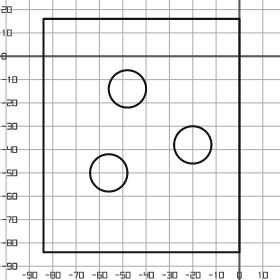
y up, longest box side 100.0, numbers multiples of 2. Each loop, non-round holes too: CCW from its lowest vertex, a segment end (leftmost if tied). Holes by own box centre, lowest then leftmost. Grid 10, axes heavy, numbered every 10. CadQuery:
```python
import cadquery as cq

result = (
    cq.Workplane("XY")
    .moveTo(-84.0, -84.0)
    .lineTo(0.0, -84.0)
    .lineTo(0.0, 16.0)
    .lineTo(-84.0, 16.0)
    .close()
    .moveTo(-56.0, -50.0)
    .circle(8.0)
    .moveTo(-20.0, -38.0)
    .circle(8.0)
    .moveTo(-48.0, -14.0)
    .circle(8.0)
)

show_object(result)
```